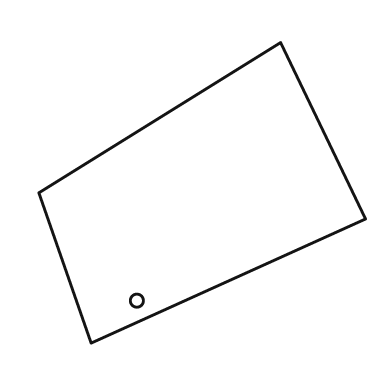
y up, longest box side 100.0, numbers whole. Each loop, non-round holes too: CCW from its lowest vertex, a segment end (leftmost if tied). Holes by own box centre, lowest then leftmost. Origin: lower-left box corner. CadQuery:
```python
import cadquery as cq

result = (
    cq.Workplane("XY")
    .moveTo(16.0, 0.0)
    .lineTo(100.0, 38.0)
    .lineTo(74.0, 92.0)
    .lineTo(0.0, 46.0)
    .close()
    .moveTo(30.0, 13.0)
    .circle(2.0)
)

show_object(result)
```